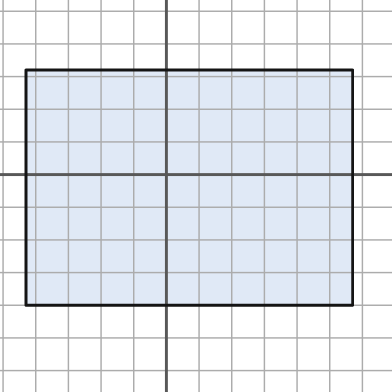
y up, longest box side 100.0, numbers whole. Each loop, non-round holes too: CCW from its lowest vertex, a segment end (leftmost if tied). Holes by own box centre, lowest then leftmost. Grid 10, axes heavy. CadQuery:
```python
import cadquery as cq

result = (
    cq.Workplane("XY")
    .moveTo(-43.0, -40.0)
    .lineTo(57.0, -40.0)
    .lineTo(57.0, 32.0)
    .lineTo(-43.0, 32.0)
    .close()
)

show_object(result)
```